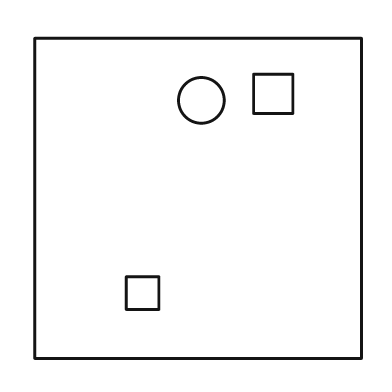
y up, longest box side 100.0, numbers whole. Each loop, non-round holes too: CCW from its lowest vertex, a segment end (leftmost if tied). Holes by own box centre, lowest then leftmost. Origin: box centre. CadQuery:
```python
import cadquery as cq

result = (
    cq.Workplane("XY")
    .moveTo(-50.0, -49.0)
    .lineTo(50.0, -49.0)
    .lineTo(50.0, 49.0)
    .lineTo(-50.0, 49.0)
    .close()
    .moveTo(-22.0, -34.0)
    .lineTo(-12.0, -34.0)
    .lineTo(-12.0, -24.0)
    .lineTo(-22.0, -24.0)
    .close()
    .moveTo(1.0, 30.0)
    .circle(7.0)
    .moveTo(17.0, 26.0)
    .lineTo(29.0, 26.0)
    .lineTo(29.0, 38.0)
    .lineTo(17.0, 38.0)
    .close()
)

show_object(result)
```